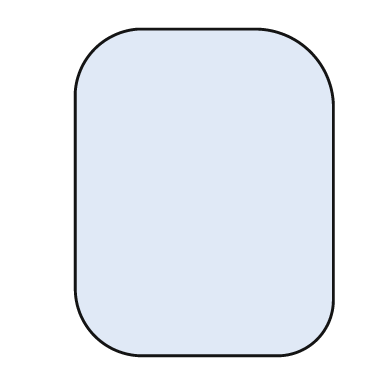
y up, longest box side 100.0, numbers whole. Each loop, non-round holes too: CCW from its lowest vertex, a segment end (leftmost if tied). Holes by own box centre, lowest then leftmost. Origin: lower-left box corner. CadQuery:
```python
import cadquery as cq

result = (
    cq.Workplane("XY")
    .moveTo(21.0, 0.0)
    .lineTo(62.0, 0.0)
    .threePointArc((74.0, 5.0), (79.0, 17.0))
    .lineTo(79.0, 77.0)
    .threePointArc((72.0, 93.0), (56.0, 100.0))
    .lineTo(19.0, 100.0)
    .threePointArc((6.0, 94.0), (0.0, 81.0))
    .lineTo(0.0, 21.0)
    .threePointArc((6.0, 6.0), (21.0, 0.0))
    .close()
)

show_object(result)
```